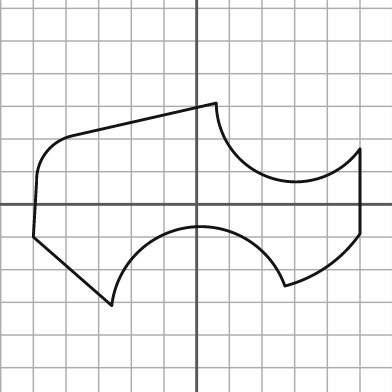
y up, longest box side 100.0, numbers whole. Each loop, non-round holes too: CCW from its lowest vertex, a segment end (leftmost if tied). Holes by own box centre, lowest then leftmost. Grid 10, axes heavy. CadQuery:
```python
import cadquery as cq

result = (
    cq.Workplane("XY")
    .moveTo(-26.0, -31.0)
    .threePointArc((-2.0, -7.0), (27.0, -25.0))
    .threePointArc((40.0, -19.0), (50.0, -9.0))
    .lineTo(50.0, 17.0)
    .threePointArc((23.0, 8.0), (6.0, 31.0))
    .lineTo(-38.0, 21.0)
    .threePointArc((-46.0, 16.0), (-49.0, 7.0))
    .lineTo(-50.0, -10.0)
    .close()
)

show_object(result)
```